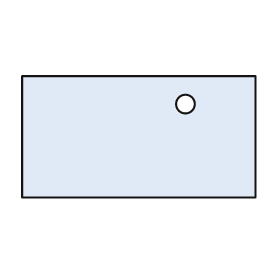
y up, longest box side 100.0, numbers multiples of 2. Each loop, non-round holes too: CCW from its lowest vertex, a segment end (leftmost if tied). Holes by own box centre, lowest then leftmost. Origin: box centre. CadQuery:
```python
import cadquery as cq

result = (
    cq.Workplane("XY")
    .moveTo(-50.0, -26.0)
    .lineTo(50.0, -26.0)
    .lineTo(50.0, 26.0)
    .lineTo(-50.0, 26.0)
    .close()
    .moveTo(20.0, 14.0)
    .circle(4.0)
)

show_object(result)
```